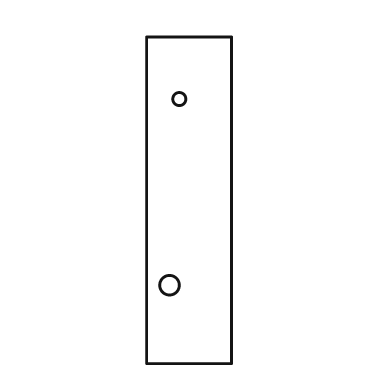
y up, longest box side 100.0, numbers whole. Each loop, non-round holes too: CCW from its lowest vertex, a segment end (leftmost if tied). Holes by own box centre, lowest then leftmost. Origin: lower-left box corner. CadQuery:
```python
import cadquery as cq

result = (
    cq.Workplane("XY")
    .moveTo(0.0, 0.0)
    .lineTo(26.0, 0.0)
    .lineTo(26.0, 100.0)
    .lineTo(0.0, 100.0)
    .close()
    .moveTo(7.0, 24.0)
    .circle(3.0)
    .moveTo(10.0, 81.0)
    .circle(2.0)
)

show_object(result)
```